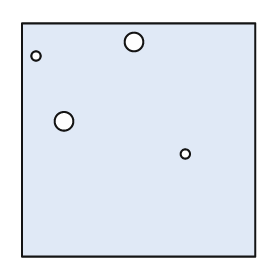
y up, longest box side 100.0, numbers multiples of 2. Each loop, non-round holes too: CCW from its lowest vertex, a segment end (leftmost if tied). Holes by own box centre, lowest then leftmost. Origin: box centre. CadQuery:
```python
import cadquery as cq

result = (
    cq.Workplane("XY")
    .moveTo(-50.0, -50.0)
    .lineTo(50.0, -50.0)
    .lineTo(50.0, 50.0)
    .lineTo(-50.0, 50.0)
    .close()
    .moveTo(20.0, -6.0)
    .circle(2.0)
    .moveTo(-32.0, 8.0)
    .circle(4.0)
    .moveTo(-44.0, 36.0)
    .circle(2.0)
    .moveTo(-2.0, 42.0)
    .circle(4.0)
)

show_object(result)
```